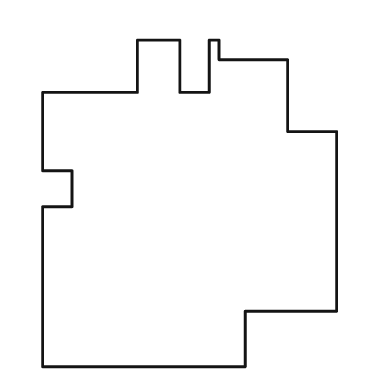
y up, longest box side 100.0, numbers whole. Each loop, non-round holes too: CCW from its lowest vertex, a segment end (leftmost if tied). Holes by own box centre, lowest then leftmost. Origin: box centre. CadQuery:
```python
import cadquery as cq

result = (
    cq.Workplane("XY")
    .moveTo(-45.0, -50.0)
    .lineTo(17.0, -50.0)
    .lineTo(17.0, -33.0)
    .lineTo(45.0, -33.0)
    .lineTo(45.0, 22.0)
    .lineTo(30.0, 22.0)
    .lineTo(30.0, 44.0)
    .lineTo(9.0, 44.0)
    .lineTo(9.0, 50.0)
    .lineTo(6.0, 50.0)
    .lineTo(6.0, 34.0)
    .lineTo(-3.0, 34.0)
    .lineTo(-3.0, 50.0)
    .lineTo(-16.0, 50.0)
    .lineTo(-16.0, 34.0)
    .lineTo(-45.0, 34.0)
    .lineTo(-45.0, 10.0)
    .lineTo(-36.0, 10.0)
    .lineTo(-36.0, -1.0)
    .lineTo(-45.0, -1.0)
    .close()
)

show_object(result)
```